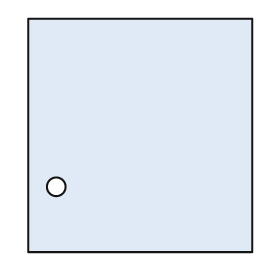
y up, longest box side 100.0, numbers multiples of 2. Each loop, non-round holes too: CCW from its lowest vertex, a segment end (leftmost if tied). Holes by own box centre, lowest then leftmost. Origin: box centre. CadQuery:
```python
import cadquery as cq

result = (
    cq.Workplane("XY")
    .moveTo(-48.0, -50.0)
    .lineTo(48.0, -50.0)
    .lineTo(48.0, 50.0)
    .lineTo(-48.0, 50.0)
    .close()
    .moveTo(-36.0, -22.0)
    .circle(4.0)
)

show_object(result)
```